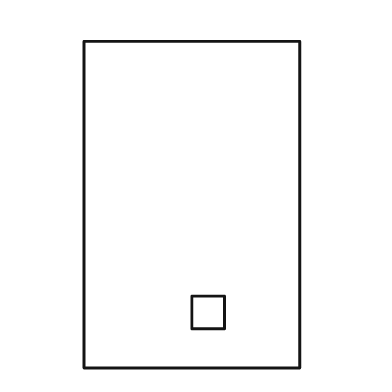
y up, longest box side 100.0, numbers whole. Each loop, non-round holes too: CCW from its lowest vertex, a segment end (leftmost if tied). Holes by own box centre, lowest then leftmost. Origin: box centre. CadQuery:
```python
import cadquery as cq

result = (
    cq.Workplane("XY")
    .moveTo(-33.0, -50.0)
    .lineTo(33.0, -50.0)
    .lineTo(33.0, 50.0)
    .lineTo(-33.0, 50.0)
    .close()
    .moveTo(0.0, -38.0)
    .lineTo(10.0, -38.0)
    .lineTo(10.0, -28.0)
    .lineTo(0.0, -28.0)
    .close()
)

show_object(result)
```